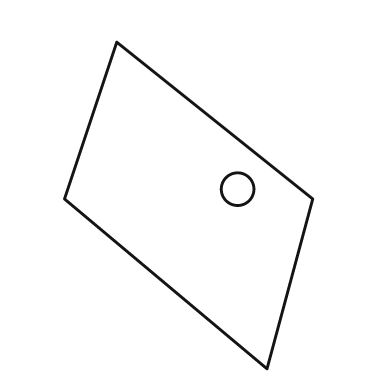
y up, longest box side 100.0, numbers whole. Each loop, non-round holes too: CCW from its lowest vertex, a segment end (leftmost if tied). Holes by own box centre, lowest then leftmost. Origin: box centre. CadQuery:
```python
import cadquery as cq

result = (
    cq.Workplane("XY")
    .moveTo(24.0, -50.0)
    .lineTo(38.0, 2.0)
    .lineTo(-22.0, 50.0)
    .lineTo(-38.0, 2.0)
    .close()
    .moveTo(15.0, 5.0)
    .circle(5.0)
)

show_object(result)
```